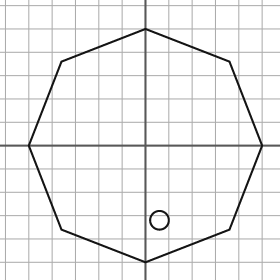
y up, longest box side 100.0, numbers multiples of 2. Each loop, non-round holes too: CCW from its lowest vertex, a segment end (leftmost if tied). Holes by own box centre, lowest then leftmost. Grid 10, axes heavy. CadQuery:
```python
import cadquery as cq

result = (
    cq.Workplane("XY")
    .moveTo(0.0, -50.0)
    .lineTo(36.0, -36.0)
    .lineTo(50.0, 0.0)
    .lineTo(36.0, 36.0)
    .lineTo(0.0, 50.0)
    .lineTo(-36.0, 36.0)
    .lineTo(-50.0, 0.0)
    .lineTo(-36.0, -36.0)
    .close()
    .moveTo(6.0, -32.0)
    .circle(4.0)
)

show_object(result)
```